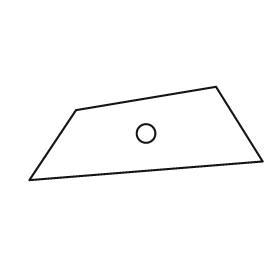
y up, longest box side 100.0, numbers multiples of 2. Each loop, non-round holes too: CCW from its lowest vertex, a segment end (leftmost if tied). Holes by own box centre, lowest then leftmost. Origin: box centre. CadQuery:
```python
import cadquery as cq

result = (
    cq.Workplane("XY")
    .moveTo(-50.0, -20.0)
    .lineTo(50.0, -12.0)
    .lineTo(30.0, 20.0)
    .lineTo(-30.0, 10.0)
    .close()
    .moveTo(0.0, 0.0)
    .circle(4.0)
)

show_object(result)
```